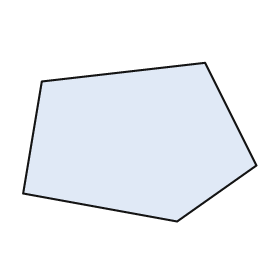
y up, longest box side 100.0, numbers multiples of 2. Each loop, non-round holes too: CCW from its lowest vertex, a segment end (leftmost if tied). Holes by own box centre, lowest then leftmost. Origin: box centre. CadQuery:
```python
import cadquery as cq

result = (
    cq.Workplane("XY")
    .moveTo(16.0, -34.0)
    .lineTo(50.0, -10.0)
    .lineTo(28.0, 34.0)
    .lineTo(-42.0, 26.0)
    .lineTo(-50.0, -22.0)
    .close()
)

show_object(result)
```